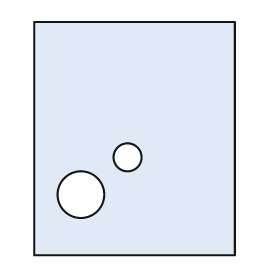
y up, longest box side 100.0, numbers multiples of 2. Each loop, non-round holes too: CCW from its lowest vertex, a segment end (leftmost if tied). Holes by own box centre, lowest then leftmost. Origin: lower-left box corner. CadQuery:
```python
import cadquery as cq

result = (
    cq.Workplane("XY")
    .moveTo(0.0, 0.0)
    .lineTo(86.0, 0.0)
    .lineTo(86.0, 100.0)
    .lineTo(0.0, 100.0)
    .close()
    .moveTo(20.0, 26.0)
    .circle(10.0)
    .moveTo(40.0, 42.0)
    .circle(6.0)
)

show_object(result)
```